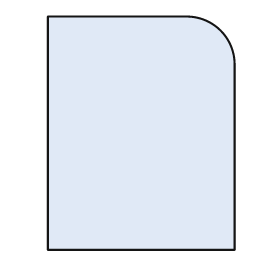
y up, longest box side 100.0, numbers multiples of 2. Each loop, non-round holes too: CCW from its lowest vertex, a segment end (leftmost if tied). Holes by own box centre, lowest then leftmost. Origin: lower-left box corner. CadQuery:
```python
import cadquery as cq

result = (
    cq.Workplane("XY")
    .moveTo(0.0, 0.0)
    .lineTo(80.0, 0.0)
    .lineTo(80.0, 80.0)
    .threePointArc((74.0, 94.0), (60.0, 100.0))
    .lineTo(0.0, 100.0)
    .close()
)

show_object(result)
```